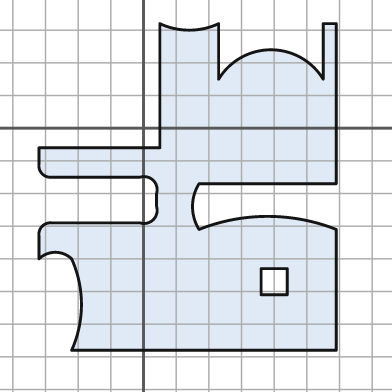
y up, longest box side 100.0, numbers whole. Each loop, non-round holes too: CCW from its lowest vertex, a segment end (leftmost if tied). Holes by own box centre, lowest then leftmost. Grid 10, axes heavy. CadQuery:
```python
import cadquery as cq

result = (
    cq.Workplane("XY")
    .moveTo(-22.0, -68.0)
    .lineTo(59.0, -68.0)
    .lineTo(59.0, -31.0)
    .threePointArc((38.0, -27.0), (17.0, -31.0))
    .threePointArc((15.0, -24.0), (17.0, -17.0))
    .lineTo(59.0, -17.0)
    .lineTo(59.0, 32.0)
    .lineTo(55.0, 32.0)
    .lineTo(55.0, 15.0)
    .threePointArc((39.0, 24.0), (23.0, 15.0))
    .lineTo(23.0, 32.0)
    .threePointArc((14.0, 30.0), (5.0, 32.0))
    .lineTo(5.0, -6.0)
    .lineTo(-32.0, -6.0)
    .lineTo(-32.0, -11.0)
    .threePointArc((-31.0, -14.0), (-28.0, -15.0))
    .lineTo(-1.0, -15.0)
    .threePointArc((3.0, -16.0), (4.0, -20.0))
    .lineTo(4.0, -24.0)
    .threePointArc((3.0, -28.0), (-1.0, -29.0))
    .lineTo(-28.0, -29.0)
    .threePointArc((-31.0, -30.0), (-32.0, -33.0))
    .lineTo(-32.0, -40.0)
    .threePointArc((-27.0, -38.0), (-22.0, -40.0))
    .threePointArc((-19.0, -54.0), (-22.0, -68.0))
    .close()
    .moveTo(36.0, -51.0)
    .lineTo(44.0, -51.0)
    .lineTo(44.0, -43.0)
    .lineTo(36.0, -43.0)
    .close()
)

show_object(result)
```